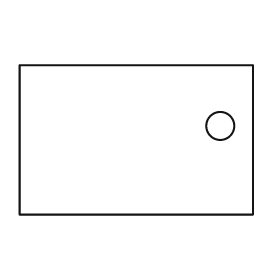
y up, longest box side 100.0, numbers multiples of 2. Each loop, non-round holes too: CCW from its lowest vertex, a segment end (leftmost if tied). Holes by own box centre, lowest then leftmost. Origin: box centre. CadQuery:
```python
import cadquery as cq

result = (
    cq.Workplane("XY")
    .moveTo(-50.0, -32.0)
    .lineTo(50.0, -32.0)
    .lineTo(50.0, 32.0)
    .lineTo(-50.0, 32.0)
    .close()
    .moveTo(36.0, 6.0)
    .circle(6.0)
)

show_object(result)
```